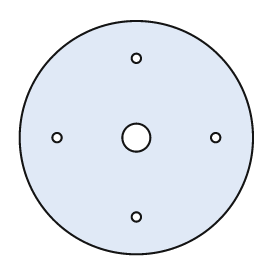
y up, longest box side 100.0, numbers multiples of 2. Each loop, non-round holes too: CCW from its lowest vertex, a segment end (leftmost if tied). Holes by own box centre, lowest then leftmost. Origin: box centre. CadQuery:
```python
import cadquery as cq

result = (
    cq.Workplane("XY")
    .moveTo(0.0, 0.0)
    .circle(50.0)
    .moveTo(0.0, -34.0)
    .circle(2.0)
    .moveTo(-34.0, 0.0)
    .circle(2.0)
    .moveTo(0.0, 0.0)
    .circle(6.0)
    .moveTo(34.0, 0.0)
    .circle(2.0)
    .moveTo(0.0, 34.0)
    .circle(2.0)
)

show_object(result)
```